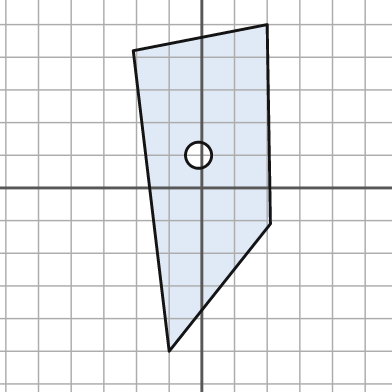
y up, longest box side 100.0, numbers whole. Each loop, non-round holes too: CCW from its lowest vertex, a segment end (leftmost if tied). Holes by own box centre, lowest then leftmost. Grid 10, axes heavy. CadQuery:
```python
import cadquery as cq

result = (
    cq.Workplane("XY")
    .moveTo(-10.0, -50.0)
    .lineTo(21.0, -11.0)
    .lineTo(20.0, 50.0)
    .lineTo(-21.0, 42.0)
    .close()
    .moveTo(-1.0, 10.0)
    .circle(4.0)
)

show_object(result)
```